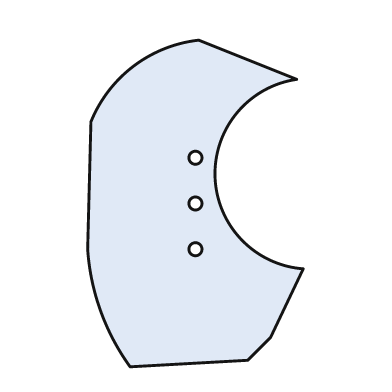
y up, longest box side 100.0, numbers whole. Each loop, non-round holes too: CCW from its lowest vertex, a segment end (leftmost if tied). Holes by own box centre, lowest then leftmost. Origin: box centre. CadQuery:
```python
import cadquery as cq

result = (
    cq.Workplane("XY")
    .moveTo(-20.0, -50.0)
    .lineTo(16.0, -48.0)
    .lineTo(23.0, -41.0)
    .lineTo(33.0, -20.0)
    .threePointArc((6.0, 8.0), (31.0, 38.0))
    .lineTo(1.0, 50.0)
    .threePointArc((-19.0, 42.0), (-32.0, 25.0))
    .lineTo(-33.0, -14.0)
    .threePointArc((-29.0, -33.0), (-20.0, -50.0))
    .close()
    .moveTo(0.0, -14.0)
    .circle(2.0)
    .moveTo(0.0, 0.0)
    .circle(2.0)
    .moveTo(0.0, 14.0)
    .circle(2.0)
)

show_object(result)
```